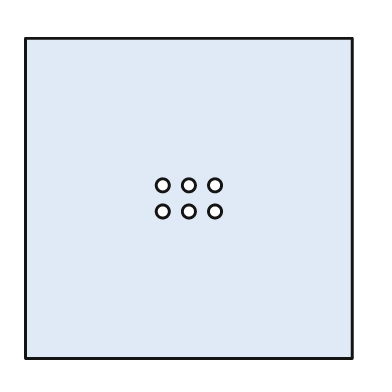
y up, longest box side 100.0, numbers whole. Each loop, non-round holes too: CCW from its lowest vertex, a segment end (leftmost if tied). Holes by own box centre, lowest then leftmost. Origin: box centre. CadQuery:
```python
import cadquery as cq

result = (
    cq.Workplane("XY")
    .moveTo(-50.0, -49.0)
    .lineTo(50.0, -49.0)
    .lineTo(50.0, 49.0)
    .lineTo(-50.0, 49.0)
    .close()
    .moveTo(-8.0, -4.0)
    .circle(2.0)
    .moveTo(0.0, -4.0)
    .circle(2.0)
    .moveTo(8.0, -4.0)
    .circle(2.0)
    .moveTo(-8.0, 4.0)
    .circle(2.0)
    .moveTo(0.0, 4.0)
    .circle(2.0)
    .moveTo(8.0, 4.0)
    .circle(2.0)
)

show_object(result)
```